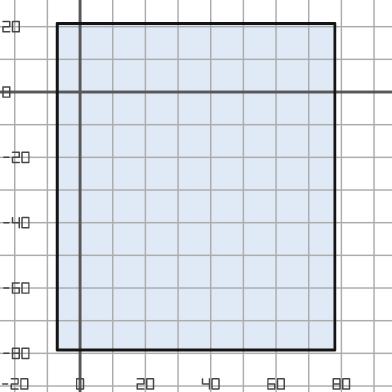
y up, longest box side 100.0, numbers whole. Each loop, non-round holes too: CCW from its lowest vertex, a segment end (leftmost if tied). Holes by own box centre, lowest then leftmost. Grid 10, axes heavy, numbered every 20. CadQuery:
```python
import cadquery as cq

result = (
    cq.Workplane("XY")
    .moveTo(-7.0, -79.0)
    .lineTo(78.0, -79.0)
    .lineTo(78.0, 21.0)
    .lineTo(-7.0, 21.0)
    .close()
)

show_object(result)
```